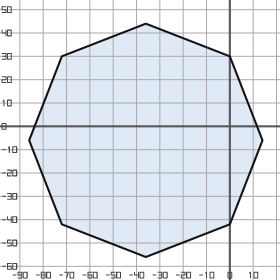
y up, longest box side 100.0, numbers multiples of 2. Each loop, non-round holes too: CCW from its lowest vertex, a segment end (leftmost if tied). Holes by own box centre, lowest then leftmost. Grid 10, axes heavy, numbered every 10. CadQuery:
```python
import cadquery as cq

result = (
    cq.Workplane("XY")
    .moveTo(-36.0, -56.0)
    .lineTo(0.0, -42.0)
    .lineTo(14.0, -6.0)
    .lineTo(0.0, 30.0)
    .lineTo(-36.0, 44.0)
    .lineTo(-72.0, 30.0)
    .lineTo(-86.0, -6.0)
    .lineTo(-72.0, -42.0)
    .close()
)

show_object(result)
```